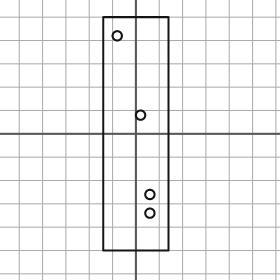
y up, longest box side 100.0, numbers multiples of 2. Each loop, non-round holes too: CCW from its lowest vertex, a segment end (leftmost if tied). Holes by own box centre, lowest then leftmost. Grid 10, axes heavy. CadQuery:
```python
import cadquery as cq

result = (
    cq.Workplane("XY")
    .moveTo(-14.0, -50.0)
    .lineTo(14.0, -50.0)
    .lineTo(14.0, 50.0)
    .lineTo(-14.0, 50.0)
    .close()
    .moveTo(6.0, -34.0)
    .circle(2.0)
    .moveTo(6.0, -26.0)
    .circle(2.0)
    .moveTo(2.0, 8.0)
    .circle(2.0)
    .moveTo(-8.0, 42.0)
    .circle(2.0)
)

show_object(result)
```